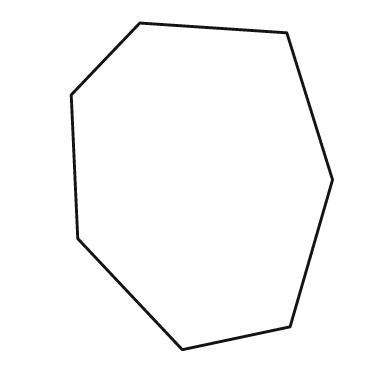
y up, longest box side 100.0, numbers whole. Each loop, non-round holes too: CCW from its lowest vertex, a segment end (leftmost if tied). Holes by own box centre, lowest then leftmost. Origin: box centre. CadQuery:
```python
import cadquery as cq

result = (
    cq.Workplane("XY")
    .moveTo(-6.0, -50.0)
    .lineTo(27.0, -43.0)
    .lineTo(40.0, 2.0)
    .lineTo(26.0, 47.0)
    .lineTo(-19.0, 50.0)
    .lineTo(-40.0, 28.0)
    .lineTo(-38.0, -16.0)
    .close()
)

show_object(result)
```